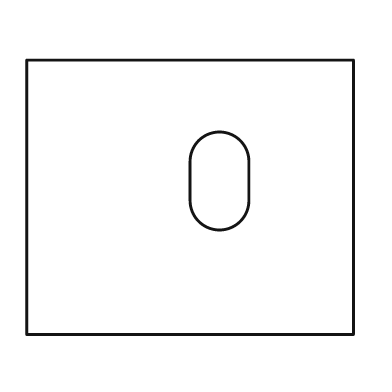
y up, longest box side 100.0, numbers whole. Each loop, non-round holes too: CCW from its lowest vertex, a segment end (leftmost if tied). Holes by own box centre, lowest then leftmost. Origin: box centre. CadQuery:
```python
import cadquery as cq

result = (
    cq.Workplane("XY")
    .moveTo(-50.0, -42.0)
    .lineTo(50.0, -42.0)
    .lineTo(50.0, 42.0)
    .lineTo(-50.0, 42.0)
    .close()
    .moveTo(0.0, -1.0)
    .threePointArc((9.0, -10.0), (18.0, -1.0))
    .lineTo(18.0, 11.0)
    .threePointArc((9.0, 20.0), (0.0, 11.0))
    .close()
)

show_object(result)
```